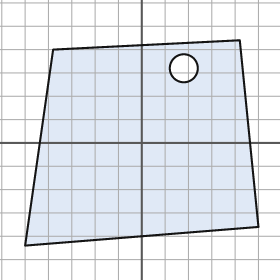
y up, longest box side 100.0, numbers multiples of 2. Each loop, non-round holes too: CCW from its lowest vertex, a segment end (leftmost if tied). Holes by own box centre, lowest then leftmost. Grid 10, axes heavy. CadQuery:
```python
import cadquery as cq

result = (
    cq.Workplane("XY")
    .moveTo(-50.0, -44.0)
    .lineTo(50.0, -36.0)
    .lineTo(42.0, 44.0)
    .lineTo(-38.0, 40.0)
    .close()
    .moveTo(18.0, 32.0)
    .circle(6.0)
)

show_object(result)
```